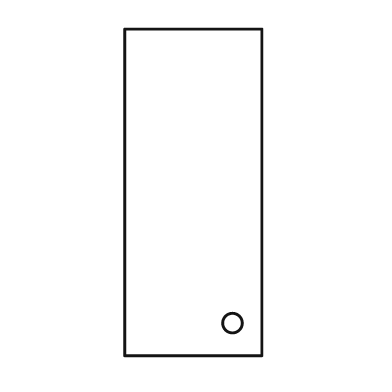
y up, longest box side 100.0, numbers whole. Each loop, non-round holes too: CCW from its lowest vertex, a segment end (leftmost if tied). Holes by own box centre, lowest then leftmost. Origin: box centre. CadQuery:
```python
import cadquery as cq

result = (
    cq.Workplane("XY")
    .moveTo(-21.0, -50.0)
    .lineTo(21.0, -50.0)
    .lineTo(21.0, 50.0)
    .lineTo(-21.0, 50.0)
    .close()
    .moveTo(12.0, -40.0)
    .circle(3.0)
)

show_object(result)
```